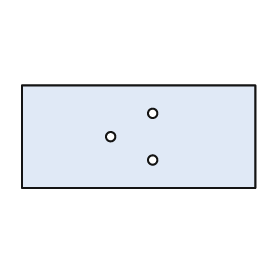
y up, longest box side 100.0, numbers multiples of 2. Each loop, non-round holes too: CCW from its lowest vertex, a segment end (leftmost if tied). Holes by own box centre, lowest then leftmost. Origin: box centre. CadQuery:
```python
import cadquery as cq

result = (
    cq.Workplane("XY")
    .moveTo(-50.0, -22.0)
    .lineTo(50.0, -22.0)
    .lineTo(50.0, 22.0)
    .lineTo(-50.0, 22.0)
    .close()
    .moveTo(6.0, -10.0)
    .circle(2.0)
    .moveTo(-12.0, 0.0)
    .circle(2.0)
    .moveTo(6.0, 10.0)
    .circle(2.0)
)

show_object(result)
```